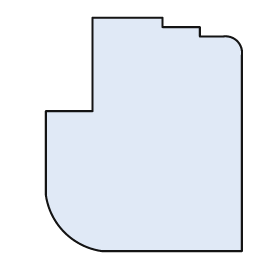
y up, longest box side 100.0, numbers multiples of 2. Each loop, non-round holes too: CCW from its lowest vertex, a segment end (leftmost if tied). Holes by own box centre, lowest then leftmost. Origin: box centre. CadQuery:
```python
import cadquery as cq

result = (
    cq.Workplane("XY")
    .moveTo(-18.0, -50.0)
    .lineTo(42.0, -50.0)
    .lineTo(42.0, 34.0)
    .threePointArc((40.0, 40.0), (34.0, 42.0))
    .lineTo(24.0, 42.0)
    .lineTo(24.0, 46.0)
    .lineTo(8.0, 46.0)
    .lineTo(8.0, 50.0)
    .lineTo(-22.0, 50.0)
    .lineTo(-22.0, 10.0)
    .lineTo(-42.0, 10.0)
    .lineTo(-42.0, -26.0)
    .threePointArc((-34.0, -42.0), (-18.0, -50.0))
    .close()
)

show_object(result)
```